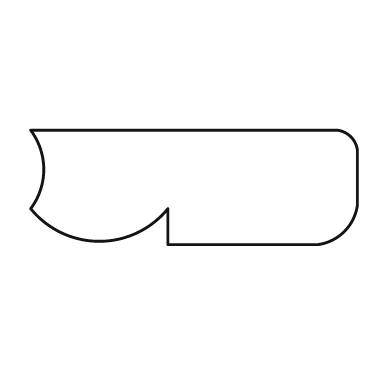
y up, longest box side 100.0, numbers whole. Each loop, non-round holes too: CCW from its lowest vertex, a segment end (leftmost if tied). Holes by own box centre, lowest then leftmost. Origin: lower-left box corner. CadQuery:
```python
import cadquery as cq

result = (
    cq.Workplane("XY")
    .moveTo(42.0, 0.0)
    .lineTo(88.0, 0.0)
    .threePointArc((96.0, 4.0), (100.0, 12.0))
    .lineTo(100.0, 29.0)
    .threePointArc((98.0, 33.0), (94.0, 35.0))
    .lineTo(0.0, 35.0)
    .threePointArc((4.0, 23.0), (0.0, 11.0))
    .threePointArc((21.0, 1.0), (42.0, 11.0))
    .close()
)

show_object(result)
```